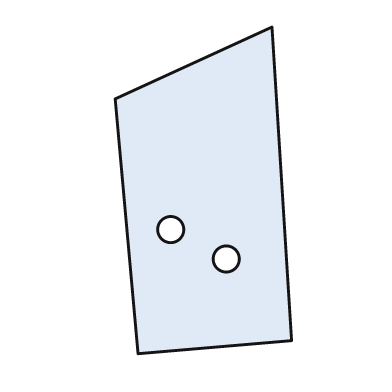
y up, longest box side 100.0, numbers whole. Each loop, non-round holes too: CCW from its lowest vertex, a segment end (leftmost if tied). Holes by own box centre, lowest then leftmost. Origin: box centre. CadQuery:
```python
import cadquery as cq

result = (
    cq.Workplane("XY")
    .moveTo(-20.0, -50.0)
    .lineTo(27.0, -46.0)
    .lineTo(21.0, 50.0)
    .lineTo(-27.0, 28.0)
    .close()
    .moveTo(7.0, -21.0)
    .circle(4.0)
    .moveTo(-10.0, -12.0)
    .circle(4.0)
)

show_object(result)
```